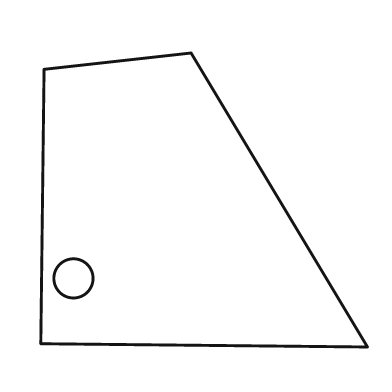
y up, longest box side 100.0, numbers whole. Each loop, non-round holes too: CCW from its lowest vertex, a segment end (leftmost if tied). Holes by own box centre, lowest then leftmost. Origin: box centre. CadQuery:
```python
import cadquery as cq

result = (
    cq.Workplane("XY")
    .moveTo(50.0, -45.0)
    .lineTo(-4.0, 45.0)
    .lineTo(-49.0, 40.0)
    .lineTo(-50.0, -44.0)
    .close()
    .moveTo(-40.0, -24.0)
    .circle(6.0)
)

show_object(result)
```